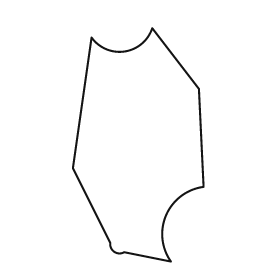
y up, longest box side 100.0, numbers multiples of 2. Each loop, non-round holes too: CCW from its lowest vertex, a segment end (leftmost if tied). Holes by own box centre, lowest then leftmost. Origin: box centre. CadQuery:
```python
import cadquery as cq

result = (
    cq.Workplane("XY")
    .moveTo(14.0, -50.0)
    .threePointArc((12.0, -30.0), (28.0, -18.0))
    .lineTo(26.0, 24.0)
    .lineTo(6.0, 50.0)
    .threePointArc((-6.0, 40.0), (-20.0, 46.0))
    .lineTo(-28.0, -10.0)
    .lineTo(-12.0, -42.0)
    .threePointArc((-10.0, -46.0), (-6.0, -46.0))
    .close()
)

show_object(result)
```